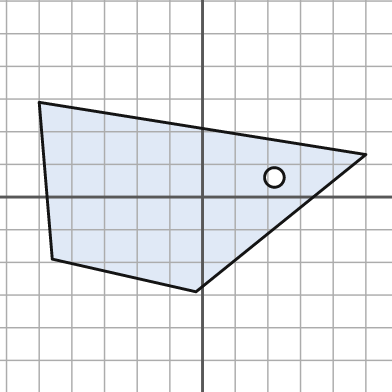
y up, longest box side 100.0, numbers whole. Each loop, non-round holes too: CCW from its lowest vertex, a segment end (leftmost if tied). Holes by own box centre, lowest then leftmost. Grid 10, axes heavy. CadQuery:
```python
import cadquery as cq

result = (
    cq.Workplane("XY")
    .moveTo(-2.0, -29.0)
    .lineTo(50.0, 13.0)
    .lineTo(-50.0, 29.0)
    .lineTo(-46.0, -19.0)
    .close()
    .moveTo(22.0, 6.0)
    .circle(3.0)
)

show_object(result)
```